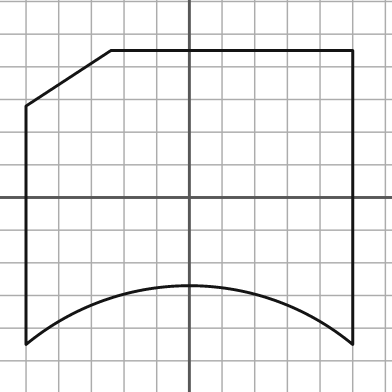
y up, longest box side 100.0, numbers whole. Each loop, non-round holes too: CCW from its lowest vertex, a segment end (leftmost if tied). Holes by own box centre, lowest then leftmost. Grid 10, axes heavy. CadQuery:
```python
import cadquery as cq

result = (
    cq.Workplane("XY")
    .moveTo(-50.0, -45.0)
    .threePointArc((0.0, -27.0), (50.0, -45.0))
    .lineTo(50.0, 45.0)
    .lineTo(-24.0, 45.0)
    .lineTo(-50.0, 28.0)
    .close()
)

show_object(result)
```